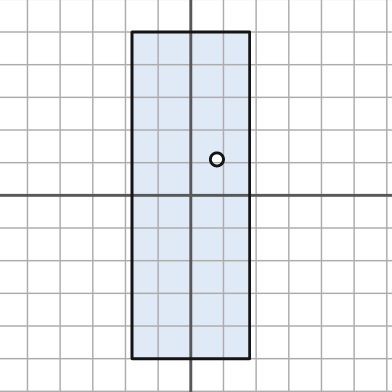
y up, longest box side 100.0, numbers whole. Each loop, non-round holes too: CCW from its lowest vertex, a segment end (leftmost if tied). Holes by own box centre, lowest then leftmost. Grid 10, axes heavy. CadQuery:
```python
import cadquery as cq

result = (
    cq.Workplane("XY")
    .moveTo(-18.0, -50.0)
    .lineTo(18.0, -50.0)
    .lineTo(18.0, 50.0)
    .lineTo(-18.0, 50.0)
    .close()
    .moveTo(8.0, 11.0)
    .circle(2.0)
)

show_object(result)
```